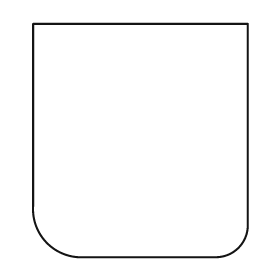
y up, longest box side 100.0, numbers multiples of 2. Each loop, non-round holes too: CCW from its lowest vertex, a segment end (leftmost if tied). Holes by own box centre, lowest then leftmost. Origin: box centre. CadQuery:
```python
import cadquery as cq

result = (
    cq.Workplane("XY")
    .moveTo(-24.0, -50.0)
    .lineTo(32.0, -50.0)
    .threePointArc((42.0, -46.0), (46.0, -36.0))
    .lineTo(46.0, 50.0)
    .lineTo(-46.0, 50.0)
    .lineTo(-46.0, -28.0)
    .threePointArc((-40.0, -44.0), (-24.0, -50.0))
    .close()
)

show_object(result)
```